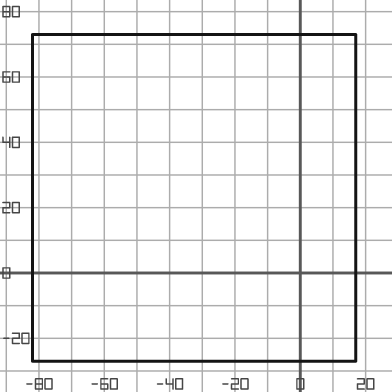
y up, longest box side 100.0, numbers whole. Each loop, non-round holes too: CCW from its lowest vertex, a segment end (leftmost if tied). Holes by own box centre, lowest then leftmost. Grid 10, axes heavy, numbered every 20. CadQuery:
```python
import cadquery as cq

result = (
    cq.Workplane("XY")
    .moveTo(-82.0, -27.0)
    .lineTo(17.0, -27.0)
    .lineTo(17.0, 73.0)
    .lineTo(-82.0, 73.0)
    .close()
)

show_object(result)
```